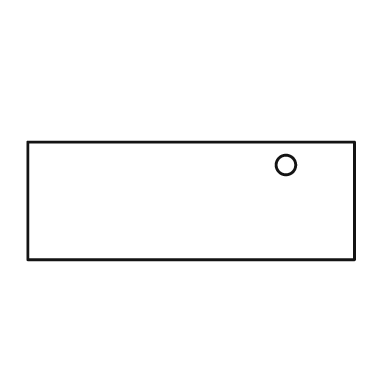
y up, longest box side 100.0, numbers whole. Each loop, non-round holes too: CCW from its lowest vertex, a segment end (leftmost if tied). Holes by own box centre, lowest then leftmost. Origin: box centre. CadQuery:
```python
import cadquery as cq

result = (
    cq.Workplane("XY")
    .moveTo(-50.0, -18.0)
    .lineTo(50.0, -18.0)
    .lineTo(50.0, 18.0)
    .lineTo(-50.0, 18.0)
    .close()
    .moveTo(29.0, 11.0)
    .circle(3.0)
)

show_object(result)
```